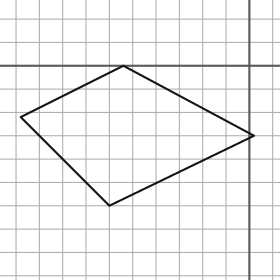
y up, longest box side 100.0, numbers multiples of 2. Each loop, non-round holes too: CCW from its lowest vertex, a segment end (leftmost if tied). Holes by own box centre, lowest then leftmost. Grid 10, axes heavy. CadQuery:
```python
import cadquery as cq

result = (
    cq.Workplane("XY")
    .moveTo(-60.0, -60.0)
    .lineTo(2.0, -30.0)
    .lineTo(-54.0, 0.0)
    .lineTo(-98.0, -22.0)
    .close()
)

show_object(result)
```